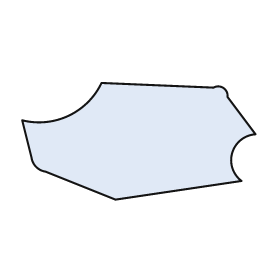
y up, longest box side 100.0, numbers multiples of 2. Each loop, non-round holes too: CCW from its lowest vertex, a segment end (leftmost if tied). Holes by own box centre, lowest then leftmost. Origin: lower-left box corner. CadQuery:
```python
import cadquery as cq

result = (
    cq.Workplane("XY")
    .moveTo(40.0, 0.0)
    .lineTo(94.0, 8.0)
    .threePointArc((90.0, 20.0), (100.0, 28.0))
    .lineTo(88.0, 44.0)
    .threePointArc((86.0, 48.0), (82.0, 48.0))
    .lineTo(34.0, 50.0)
    .threePointArc((20.0, 36.0), (0.0, 34.0))
    .lineTo(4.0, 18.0)
    .threePointArc((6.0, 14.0), (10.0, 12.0))
    .close()
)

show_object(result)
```